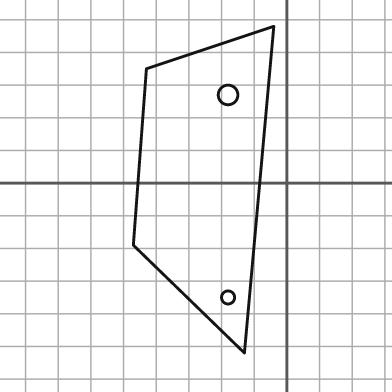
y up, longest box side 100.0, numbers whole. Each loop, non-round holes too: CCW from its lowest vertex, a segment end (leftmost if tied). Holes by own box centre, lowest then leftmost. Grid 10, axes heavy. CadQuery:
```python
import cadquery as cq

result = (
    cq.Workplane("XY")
    .moveTo(-13.0, -52.0)
    .lineTo(-4.0, 48.0)
    .lineTo(-43.0, 35.0)
    .lineTo(-47.0, -19.0)
    .close()
    .moveTo(-18.0, -35.0)
    .circle(2.0)
    .moveTo(-18.0, 27.0)
    .circle(3.0)
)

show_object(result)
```